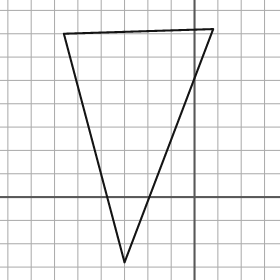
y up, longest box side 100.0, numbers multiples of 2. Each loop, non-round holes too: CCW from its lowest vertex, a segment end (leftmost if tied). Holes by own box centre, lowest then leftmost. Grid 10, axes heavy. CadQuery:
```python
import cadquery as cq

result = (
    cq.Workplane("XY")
    .moveTo(-30.0, -28.0)
    .lineTo(8.0, 72.0)
    .lineTo(-56.0, 70.0)
    .close()
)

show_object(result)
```